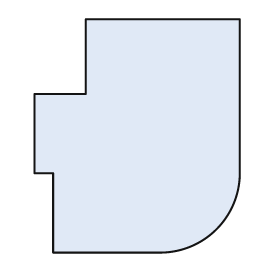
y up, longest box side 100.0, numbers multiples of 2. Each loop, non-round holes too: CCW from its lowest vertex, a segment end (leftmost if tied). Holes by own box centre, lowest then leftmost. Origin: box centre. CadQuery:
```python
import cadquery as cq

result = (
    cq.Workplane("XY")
    .moveTo(-36.0, -50.0)
    .lineTo(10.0, -50.0)
    .threePointArc((34.0, -40.0), (44.0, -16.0))
    .lineTo(44.0, 50.0)
    .lineTo(-22.0, 50.0)
    .lineTo(-22.0, 18.0)
    .lineTo(-44.0, 18.0)
    .lineTo(-44.0, -16.0)
    .lineTo(-36.0, -16.0)
    .close()
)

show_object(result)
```